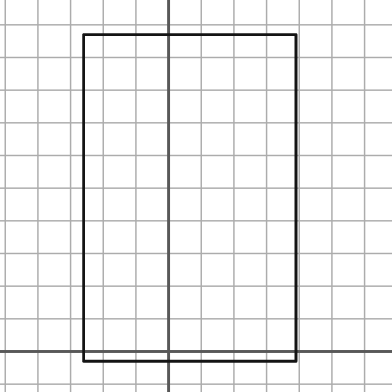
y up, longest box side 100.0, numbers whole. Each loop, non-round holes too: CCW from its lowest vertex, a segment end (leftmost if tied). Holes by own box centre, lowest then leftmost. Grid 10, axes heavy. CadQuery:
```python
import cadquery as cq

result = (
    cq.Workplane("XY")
    .moveTo(-26.0, -3.0)
    .lineTo(39.0, -3.0)
    .lineTo(39.0, 97.0)
    .lineTo(-26.0, 97.0)
    .close()
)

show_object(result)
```